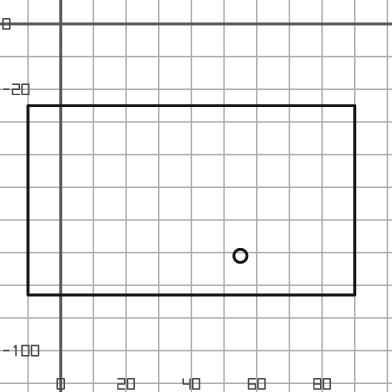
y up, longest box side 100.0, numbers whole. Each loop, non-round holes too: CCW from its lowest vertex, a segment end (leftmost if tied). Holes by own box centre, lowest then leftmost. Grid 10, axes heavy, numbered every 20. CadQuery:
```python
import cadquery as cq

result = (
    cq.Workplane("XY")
    .moveTo(-10.0, -83.0)
    .lineTo(90.0, -83.0)
    .lineTo(90.0, -25.0)
    .lineTo(-10.0, -25.0)
    .close()
    .moveTo(55.0, -71.0)
    .circle(2.0)
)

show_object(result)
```